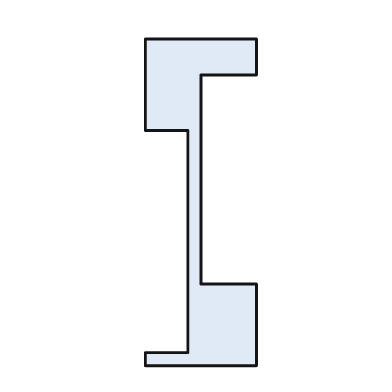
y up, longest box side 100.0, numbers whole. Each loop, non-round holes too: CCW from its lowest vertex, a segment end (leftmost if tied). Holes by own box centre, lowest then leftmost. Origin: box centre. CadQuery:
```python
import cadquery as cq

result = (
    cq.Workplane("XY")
    .moveTo(-17.0, -50.0)
    .lineTo(17.0, -50.0)
    .lineTo(17.0, -25.0)
    .lineTo(0.0, -25.0)
    .lineTo(0.0, 39.0)
    .lineTo(17.0, 39.0)
    .lineTo(17.0, 50.0)
    .lineTo(-17.0, 50.0)
    .lineTo(-17.0, 22.0)
    .lineTo(-4.0, 22.0)
    .lineTo(-4.0, -46.0)
    .lineTo(-17.0, -46.0)
    .close()
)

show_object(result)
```